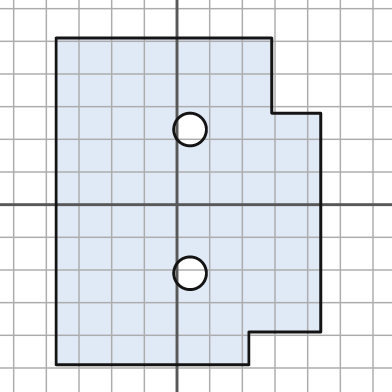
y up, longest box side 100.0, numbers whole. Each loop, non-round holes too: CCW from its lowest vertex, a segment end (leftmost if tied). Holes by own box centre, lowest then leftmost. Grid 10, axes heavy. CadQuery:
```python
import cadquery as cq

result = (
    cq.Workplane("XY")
    .moveTo(-37.0, -49.0)
    .lineTo(22.0, -49.0)
    .lineTo(22.0, -39.0)
    .lineTo(44.0, -39.0)
    .lineTo(44.0, 28.0)
    .lineTo(29.0, 28.0)
    .lineTo(29.0, 51.0)
    .lineTo(-37.0, 51.0)
    .close()
    .moveTo(4.0, -21.0)
    .circle(5.0)
    .moveTo(4.0, 23.0)
    .circle(5.0)
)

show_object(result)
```